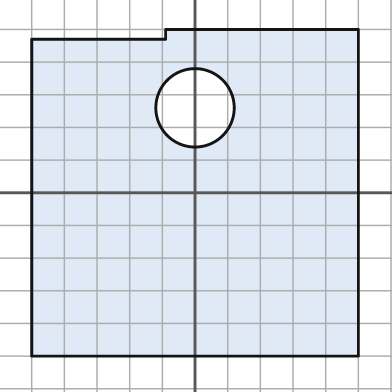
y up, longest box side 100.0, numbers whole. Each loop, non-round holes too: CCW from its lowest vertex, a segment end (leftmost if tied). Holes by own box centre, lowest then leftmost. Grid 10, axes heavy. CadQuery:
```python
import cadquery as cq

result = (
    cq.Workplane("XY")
    .moveTo(-50.0, -50.0)
    .lineTo(50.0, -50.0)
    .lineTo(50.0, 50.0)
    .lineTo(-9.0, 50.0)
    .lineTo(-9.0, 47.0)
    .lineTo(-50.0, 47.0)
    .close()
    .moveTo(0.0, 26.0)
    .circle(12.0)
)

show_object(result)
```